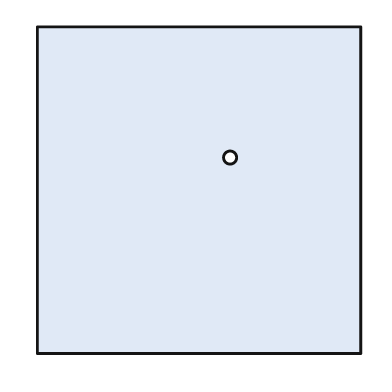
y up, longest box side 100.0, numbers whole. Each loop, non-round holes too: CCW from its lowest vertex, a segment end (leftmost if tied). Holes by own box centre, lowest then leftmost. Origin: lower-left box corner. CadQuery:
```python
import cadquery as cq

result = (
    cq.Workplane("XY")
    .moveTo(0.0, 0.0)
    .lineTo(99.0, 0.0)
    .lineTo(99.0, 100.0)
    .lineTo(0.0, 100.0)
    .close()
    .moveTo(59.0, 60.0)
    .circle(2.0)
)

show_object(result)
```